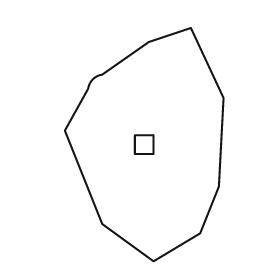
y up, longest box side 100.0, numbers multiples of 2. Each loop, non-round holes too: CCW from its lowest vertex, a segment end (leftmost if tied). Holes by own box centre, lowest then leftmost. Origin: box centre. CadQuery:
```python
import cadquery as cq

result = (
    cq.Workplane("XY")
    .moveTo(4.0, -50.0)
    .lineTo(24.0, -38.0)
    .lineTo(32.0, -18.0)
    .lineTo(34.0, 20.0)
    .lineTo(20.0, 50.0)
    .lineTo(2.0, 44.0)
    .lineTo(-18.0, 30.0)
    .threePointArc((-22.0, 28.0), (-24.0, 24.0))
    .lineTo(-34.0, 6.0)
    .lineTo(-18.0, -34.0)
    .close()
    .moveTo(-4.0, -4.0)
    .lineTo(4.0, -4.0)
    .lineTo(4.0, 4.0)
    .lineTo(-4.0, 4.0)
    .close()
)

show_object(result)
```